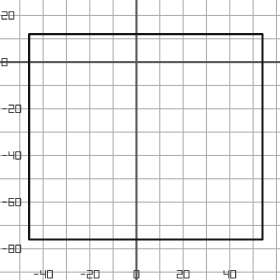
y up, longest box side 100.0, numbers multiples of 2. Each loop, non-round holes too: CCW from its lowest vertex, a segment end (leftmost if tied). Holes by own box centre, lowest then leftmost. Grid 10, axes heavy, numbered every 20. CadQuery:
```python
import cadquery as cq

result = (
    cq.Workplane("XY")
    .moveTo(-46.0, -76.0)
    .lineTo(54.0, -76.0)
    .lineTo(54.0, 12.0)
    .lineTo(-46.0, 12.0)
    .close()
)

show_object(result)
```